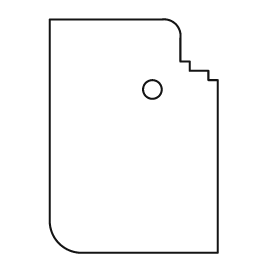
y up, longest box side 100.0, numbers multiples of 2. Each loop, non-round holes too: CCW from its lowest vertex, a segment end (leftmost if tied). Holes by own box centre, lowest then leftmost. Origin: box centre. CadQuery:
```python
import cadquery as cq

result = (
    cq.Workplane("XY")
    .moveTo(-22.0, -50.0)
    .lineTo(36.0, -50.0)
    .lineTo(36.0, 24.0)
    .lineTo(32.0, 24.0)
    .lineTo(32.0, 28.0)
    .lineTo(24.0, 28.0)
    .lineTo(24.0, 32.0)
    .lineTo(20.0, 32.0)
    .lineTo(20.0, 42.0)
    .threePointArc((18.0, 48.0), (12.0, 50.0))
    .lineTo(-36.0, 50.0)
    .lineTo(-36.0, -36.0)
    .threePointArc((-32.0, -46.0), (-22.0, -50.0))
    .close()
    .moveTo(8.0, 20.0)
    .circle(4.0)
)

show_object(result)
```